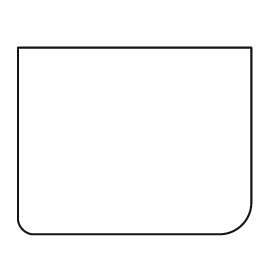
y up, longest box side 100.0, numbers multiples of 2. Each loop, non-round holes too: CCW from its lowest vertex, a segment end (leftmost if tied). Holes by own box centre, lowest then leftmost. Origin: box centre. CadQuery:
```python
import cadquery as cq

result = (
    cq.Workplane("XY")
    .moveTo(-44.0, -40.0)
    .lineTo(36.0, -40.0)
    .threePointArc((46.0, -36.0), (50.0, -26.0))
    .lineTo(50.0, 40.0)
    .lineTo(-50.0, 40.0)
    .lineTo(-50.0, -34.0)
    .threePointArc((-48.0, -38.0), (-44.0, -40.0))
    .close()
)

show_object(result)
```